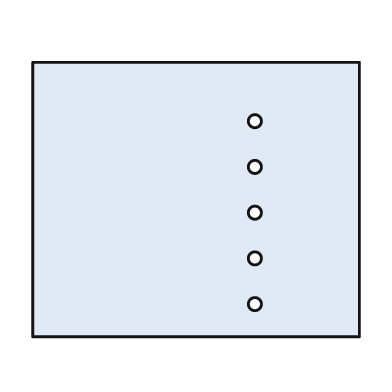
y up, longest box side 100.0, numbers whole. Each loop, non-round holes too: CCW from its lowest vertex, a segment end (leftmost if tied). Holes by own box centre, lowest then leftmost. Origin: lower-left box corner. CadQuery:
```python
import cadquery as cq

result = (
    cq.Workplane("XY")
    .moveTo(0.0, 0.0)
    .lineTo(100.0, 0.0)
    .lineTo(100.0, 84.0)
    .lineTo(0.0, 84.0)
    .close()
    .moveTo(68.0, 10.0)
    .circle(2.0)
    .moveTo(68.0, 24.0)
    .circle(2.0)
    .moveTo(68.0, 38.0)
    .circle(2.0)
    .moveTo(68.0, 52.0)
    .circle(2.0)
    .moveTo(68.0, 66.0)
    .circle(2.0)
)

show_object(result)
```